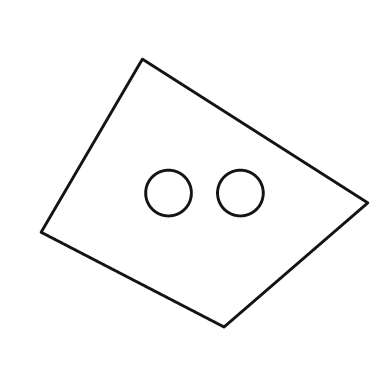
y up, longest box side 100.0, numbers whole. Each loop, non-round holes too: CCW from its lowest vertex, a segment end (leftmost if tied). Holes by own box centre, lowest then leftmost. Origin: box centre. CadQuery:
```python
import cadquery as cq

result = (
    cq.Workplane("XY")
    .moveTo(6.0, -41.0)
    .lineTo(50.0, -3.0)
    .lineTo(-19.0, 41.0)
    .lineTo(-50.0, -12.0)
    .close()
    .moveTo(-11.0, 0.0)
    .circle(7.0)
    .moveTo(11.0, 0.0)
    .circle(7.0)
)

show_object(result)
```